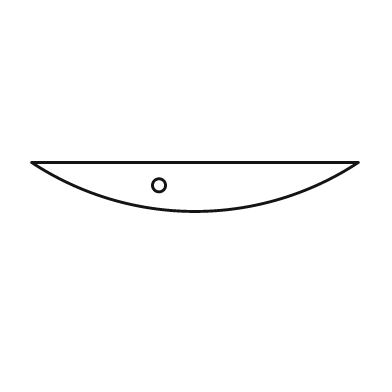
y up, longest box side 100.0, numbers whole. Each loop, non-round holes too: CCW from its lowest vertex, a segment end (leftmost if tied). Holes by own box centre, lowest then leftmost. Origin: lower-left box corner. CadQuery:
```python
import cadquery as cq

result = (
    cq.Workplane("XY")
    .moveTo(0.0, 15.0)
    .threePointArc((50.0, 0.0), (100.0, 15.0))
    .close()
    .moveTo(39.0, 8.0)
    .circle(2.0)
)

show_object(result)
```